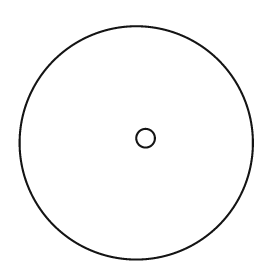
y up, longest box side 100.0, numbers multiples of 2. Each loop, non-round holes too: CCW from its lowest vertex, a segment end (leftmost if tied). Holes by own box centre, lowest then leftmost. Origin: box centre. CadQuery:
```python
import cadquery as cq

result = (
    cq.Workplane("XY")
    .moveTo(0.0, 0.0)
    .circle(50.0)
    .moveTo(4.0, 2.0)
    .circle(4.0)
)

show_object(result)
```